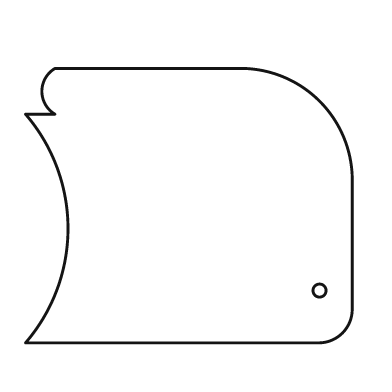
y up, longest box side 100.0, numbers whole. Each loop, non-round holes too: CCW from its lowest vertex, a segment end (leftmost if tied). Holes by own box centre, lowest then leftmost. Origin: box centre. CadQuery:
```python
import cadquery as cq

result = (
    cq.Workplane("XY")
    .moveTo(-50.0, -42.0)
    .lineTo(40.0, -42.0)
    .threePointArc((47.0, -39.0), (50.0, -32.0))
    .lineTo(50.0, 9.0)
    .threePointArc((40.0, 32.0), (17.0, 42.0))
    .lineTo(-41.0, 42.0)
    .threePointArc((-45.0, 35.0), (-41.0, 28.0))
    .lineTo(-50.0, 28.0)
    .threePointArc((-37.0, -7.0), (-50.0, -42.0))
    .close()
    .moveTo(40.0, -26.0)
    .circle(2.0)
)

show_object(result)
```